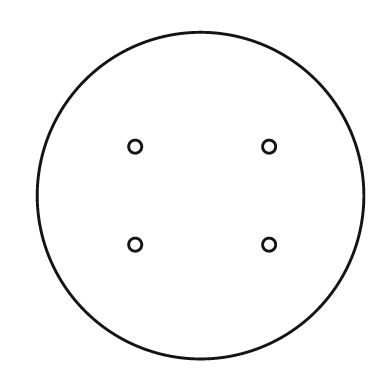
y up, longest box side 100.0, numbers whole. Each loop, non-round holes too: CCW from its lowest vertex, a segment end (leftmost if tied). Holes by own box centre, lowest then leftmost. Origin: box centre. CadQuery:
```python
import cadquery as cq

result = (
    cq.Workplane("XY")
    .moveTo(0.0, 0.0)
    .circle(50.0)
    .moveTo(-20.0, -15.0)
    .circle(2.0)
    .moveTo(21.0, -15.0)
    .circle(2.0)
    .moveTo(-20.0, 15.0)
    .circle(2.0)
    .moveTo(21.0, 15.0)
    .circle(2.0)
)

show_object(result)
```